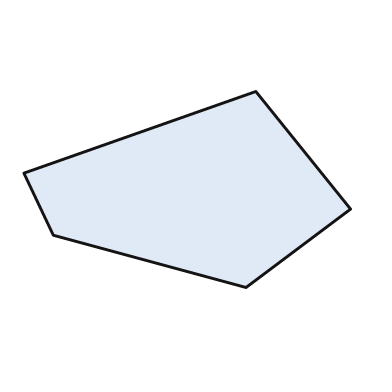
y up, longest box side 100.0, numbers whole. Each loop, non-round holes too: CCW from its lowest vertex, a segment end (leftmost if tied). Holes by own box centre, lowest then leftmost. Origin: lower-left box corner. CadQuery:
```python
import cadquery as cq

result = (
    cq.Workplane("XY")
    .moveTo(68.0, 0.0)
    .lineTo(100.0, 24.0)
    .lineTo(71.0, 60.0)
    .lineTo(0.0, 35.0)
    .lineTo(9.0, 16.0)
    .close()
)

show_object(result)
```